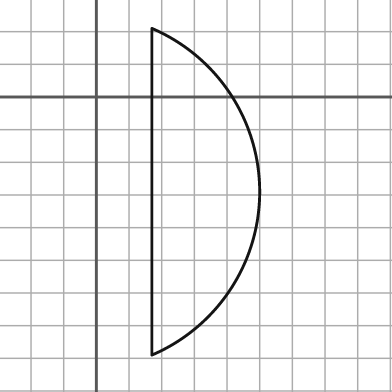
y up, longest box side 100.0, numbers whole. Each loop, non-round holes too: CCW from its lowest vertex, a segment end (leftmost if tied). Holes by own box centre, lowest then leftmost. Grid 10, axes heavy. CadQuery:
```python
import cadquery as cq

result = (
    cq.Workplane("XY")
    .moveTo(17.0, -79.0)
    .threePointArc((50.0, -29.0), (17.0, 21.0))
    .close()
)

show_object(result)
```